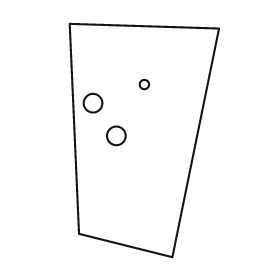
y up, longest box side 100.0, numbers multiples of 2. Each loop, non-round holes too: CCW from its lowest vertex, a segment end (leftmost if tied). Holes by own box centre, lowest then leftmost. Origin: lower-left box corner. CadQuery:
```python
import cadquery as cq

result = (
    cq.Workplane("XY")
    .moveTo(44.0, 0.0)
    .lineTo(64.0, 98.0)
    .lineTo(0.0, 100.0)
    .lineTo(4.0, 10.0)
    .close()
    .moveTo(20.0, 52.0)
    .circle(4.0)
    .moveTo(10.0, 66.0)
    .circle(4.0)
    .moveTo(32.0, 74.0)
    .circle(2.0)
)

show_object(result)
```